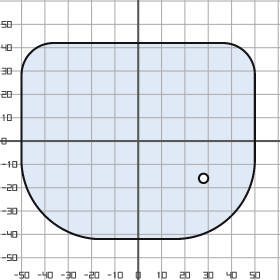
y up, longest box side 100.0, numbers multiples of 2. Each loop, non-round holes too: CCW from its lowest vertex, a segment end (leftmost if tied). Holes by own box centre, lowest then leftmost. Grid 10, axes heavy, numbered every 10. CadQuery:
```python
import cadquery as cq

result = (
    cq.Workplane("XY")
    .moveTo(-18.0, -42.0)
    .lineTo(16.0, -42.0)
    .threePointArc((40.0, -32.0), (50.0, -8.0))
    .lineTo(50.0, 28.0)
    .threePointArc((46.0, 38.0), (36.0, 42.0))
    .lineTo(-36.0, 42.0)
    .threePointArc((-46.0, 38.0), (-50.0, 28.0))
    .lineTo(-50.0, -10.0)
    .threePointArc((-40.0, -32.0), (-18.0, -42.0))
    .close()
    .moveTo(28.0, -16.0)
    .circle(2.0)
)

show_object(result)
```